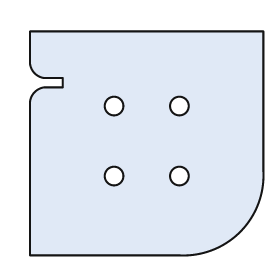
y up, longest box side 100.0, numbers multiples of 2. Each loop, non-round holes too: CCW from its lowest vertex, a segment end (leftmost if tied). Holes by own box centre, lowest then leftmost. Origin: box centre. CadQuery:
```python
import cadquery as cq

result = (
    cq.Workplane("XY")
    .moveTo(-50.0, -48.0)
    .lineTo(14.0, -48.0)
    .threePointArc((40.0, -38.0), (50.0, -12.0))
    .lineTo(50.0, 48.0)
    .lineTo(-50.0, 48.0)
    .lineTo(-50.0, 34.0)
    .threePointArc((-48.0, 30.0), (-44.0, 28.0))
    .lineTo(-36.0, 28.0)
    .lineTo(-36.0, 24.0)
    .lineTo(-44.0, 24.0)
    .threePointArc((-48.0, 22.0), (-50.0, 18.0))
    .close()
    .moveTo(-14.0, -14.0)
    .circle(4.0)
    .moveTo(14.0, -14.0)
    .circle(4.0)
    .moveTo(-14.0, 16.0)
    .circle(4.0)
    .moveTo(14.0, 16.0)
    .circle(4.0)
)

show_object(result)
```